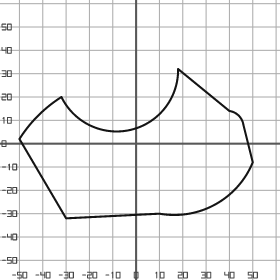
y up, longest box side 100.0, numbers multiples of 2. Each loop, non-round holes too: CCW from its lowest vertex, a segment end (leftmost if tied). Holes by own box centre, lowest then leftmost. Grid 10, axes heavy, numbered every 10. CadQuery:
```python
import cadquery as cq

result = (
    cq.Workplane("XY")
    .moveTo(-30.0, -32.0)
    .lineTo(10.0, -30.0)
    .threePointArc((34.0, -26.0), (50.0, -8.0))
    .lineTo(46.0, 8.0)
    .threePointArc((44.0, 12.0), (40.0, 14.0))
    .lineTo(18.0, 32.0)
    .threePointArc((-2.0, 6.0), (-32.0, 20.0))
    .threePointArc((-42.0, 12.0), (-50.0, 2.0))
    .close()
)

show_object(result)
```